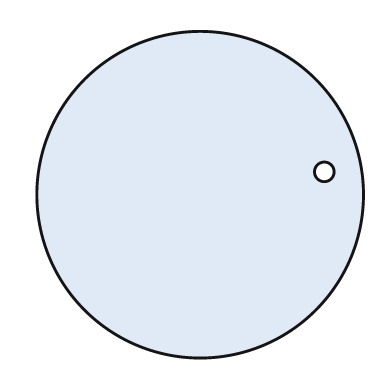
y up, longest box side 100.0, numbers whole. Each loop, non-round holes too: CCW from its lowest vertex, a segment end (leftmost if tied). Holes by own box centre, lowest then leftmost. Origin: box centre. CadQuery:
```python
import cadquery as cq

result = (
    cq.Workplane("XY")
    .moveTo(0.0, 0.0)
    .circle(50.0)
    .moveTo(38.0, 7.0)
    .circle(3.0)
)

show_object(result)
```